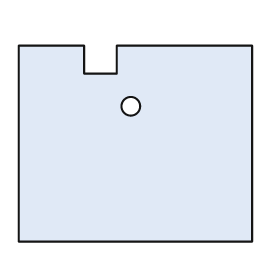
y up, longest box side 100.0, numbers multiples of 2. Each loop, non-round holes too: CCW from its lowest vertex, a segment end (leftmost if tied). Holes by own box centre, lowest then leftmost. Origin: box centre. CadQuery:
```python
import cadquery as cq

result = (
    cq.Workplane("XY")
    .moveTo(-50.0, -42.0)
    .lineTo(50.0, -42.0)
    .lineTo(50.0, 42.0)
    .lineTo(-8.0, 42.0)
    .lineTo(-8.0, 30.0)
    .lineTo(-22.0, 30.0)
    .lineTo(-22.0, 42.0)
    .lineTo(-50.0, 42.0)
    .close()
    .moveTo(-2.0, 16.0)
    .circle(4.0)
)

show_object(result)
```